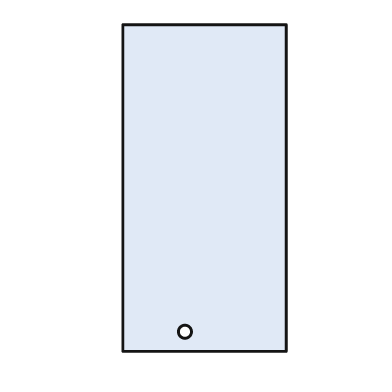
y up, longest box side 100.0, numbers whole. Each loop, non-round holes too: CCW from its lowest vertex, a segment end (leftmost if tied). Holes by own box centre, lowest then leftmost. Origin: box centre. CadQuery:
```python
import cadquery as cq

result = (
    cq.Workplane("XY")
    .moveTo(-25.0, -50.0)
    .lineTo(25.0, -50.0)
    .lineTo(25.0, 50.0)
    .lineTo(-25.0, 50.0)
    .close()
    .moveTo(-6.0, -44.0)
    .circle(2.0)
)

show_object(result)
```